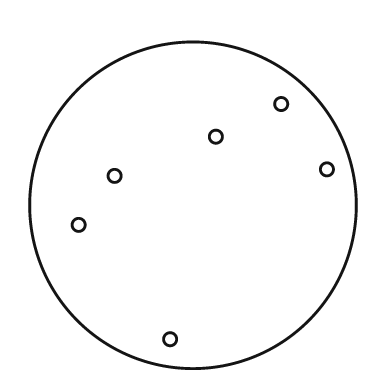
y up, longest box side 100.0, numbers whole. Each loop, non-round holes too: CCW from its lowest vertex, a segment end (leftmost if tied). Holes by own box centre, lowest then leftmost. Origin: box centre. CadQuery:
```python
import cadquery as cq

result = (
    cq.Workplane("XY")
    .moveTo(0.0, 0.0)
    .circle(50.0)
    .moveTo(-7.0, -41.0)
    .circle(2.0)
    .moveTo(-35.0, -6.0)
    .circle(2.0)
    .moveTo(-24.0, 9.0)
    .circle(2.0)
    .moveTo(41.0, 11.0)
    .circle(2.0)
    .moveTo(7.0, 21.0)
    .circle(2.0)
    .moveTo(27.0, 31.0)
    .circle(2.0)
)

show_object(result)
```